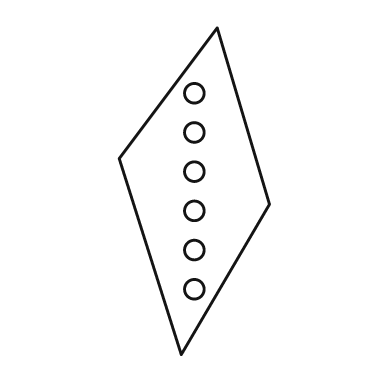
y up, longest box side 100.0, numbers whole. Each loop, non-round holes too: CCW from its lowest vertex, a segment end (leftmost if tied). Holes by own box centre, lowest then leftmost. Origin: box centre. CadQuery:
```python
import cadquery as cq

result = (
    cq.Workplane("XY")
    .moveTo(-4.0, -50.0)
    .lineTo(23.0, -4.0)
    .lineTo(7.0, 50.0)
    .lineTo(-23.0, 10.0)
    .close()
    .moveTo(0.0, -30.0)
    .circle(3.0)
    .moveTo(0.0, -18.0)
    .circle(3.0)
    .moveTo(0.0, -6.0)
    .circle(3.0)
    .moveTo(0.0, 6.0)
    .circle(3.0)
    .moveTo(0.0, 18.0)
    .circle(3.0)
    .moveTo(0.0, 30.0)
    .circle(3.0)
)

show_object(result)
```